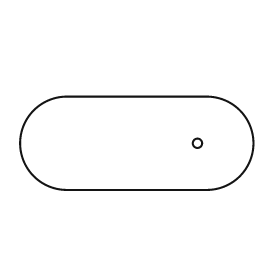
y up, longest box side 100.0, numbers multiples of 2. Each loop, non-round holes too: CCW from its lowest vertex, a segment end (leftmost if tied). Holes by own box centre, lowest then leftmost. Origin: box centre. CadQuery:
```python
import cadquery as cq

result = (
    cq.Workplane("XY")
    .moveTo(-30.0, -20.0)
    .lineTo(30.0, -20.0)
    .threePointArc((50.0, 0.0), (30.0, 20.0))
    .lineTo(-30.0, 20.0)
    .threePointArc((-50.0, 0.0), (-30.0, -20.0))
    .close()
    .moveTo(26.0, 0.0)
    .circle(2.0)
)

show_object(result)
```